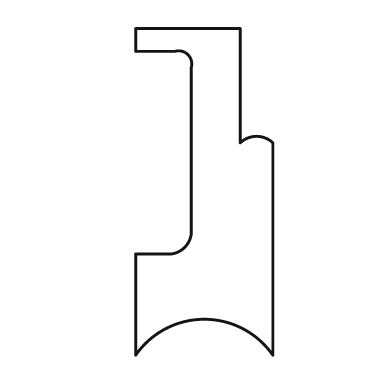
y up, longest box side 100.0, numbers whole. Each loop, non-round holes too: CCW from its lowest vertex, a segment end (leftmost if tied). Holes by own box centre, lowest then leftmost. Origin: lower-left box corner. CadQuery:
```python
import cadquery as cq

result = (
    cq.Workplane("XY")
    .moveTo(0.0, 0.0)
    .threePointArc((21.0, 11.0), (42.0, 0.0))
    .lineTo(42.0, 65.0)
    .threePointArc((37.0, 67.0), (32.0, 65.0))
    .lineTo(32.0, 100.0)
    .lineTo(0.0, 100.0)
    .lineTo(0.0, 93.0)
    .lineTo(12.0, 93.0)
    .threePointArc((16.0, 92.0), (17.0, 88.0))
    .lineTo(17.0, 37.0)
    .threePointArc((15.0, 33.0), (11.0, 31.0))
    .lineTo(0.0, 31.0)
    .close()
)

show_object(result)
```